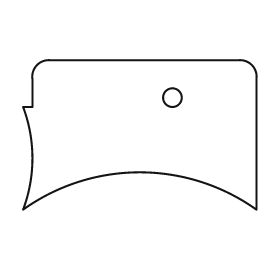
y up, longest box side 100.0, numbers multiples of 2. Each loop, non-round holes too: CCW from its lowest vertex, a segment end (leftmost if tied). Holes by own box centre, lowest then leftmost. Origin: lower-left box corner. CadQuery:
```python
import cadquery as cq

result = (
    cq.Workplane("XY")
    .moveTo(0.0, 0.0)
    .threePointArc((50.0, 16.0), (100.0, 0.0))
    .lineTo(100.0, 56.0)
    .threePointArc((98.0, 62.0), (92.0, 64.0))
    .lineTo(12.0, 64.0)
    .threePointArc((6.0, 62.0), (4.0, 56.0))
    .lineTo(4.0, 44.0)
    .lineTo(0.0, 44.0)
    .threePointArc((4.0, 22.0), (0.0, 0.0))
    .close()
    .moveTo(64.0, 48.0)
    .circle(4.0)
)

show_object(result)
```